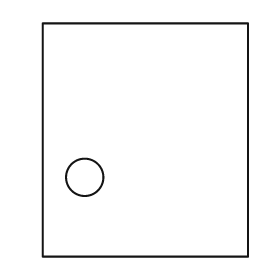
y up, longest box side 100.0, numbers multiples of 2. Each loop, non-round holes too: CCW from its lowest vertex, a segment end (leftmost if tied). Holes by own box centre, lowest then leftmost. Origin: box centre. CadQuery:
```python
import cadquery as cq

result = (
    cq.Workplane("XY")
    .moveTo(-44.0, -50.0)
    .lineTo(44.0, -50.0)
    .lineTo(44.0, 50.0)
    .lineTo(-44.0, 50.0)
    .close()
    .moveTo(-26.0, -16.0)
    .circle(8.0)
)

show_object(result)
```